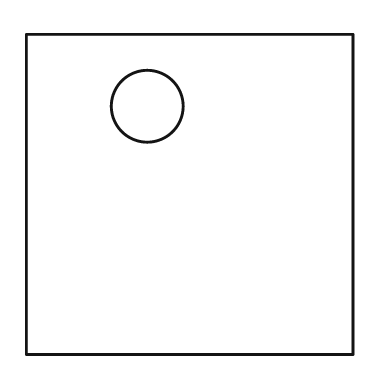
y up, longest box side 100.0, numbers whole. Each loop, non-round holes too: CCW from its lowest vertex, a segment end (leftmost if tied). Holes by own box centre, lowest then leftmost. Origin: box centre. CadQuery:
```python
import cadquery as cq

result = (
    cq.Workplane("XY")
    .moveTo(-50.0, -49.0)
    .lineTo(50.0, -49.0)
    .lineTo(50.0, 49.0)
    .lineTo(-50.0, 49.0)
    .close()
    .moveTo(-13.0, 27.0)
    .circle(11.0)
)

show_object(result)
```